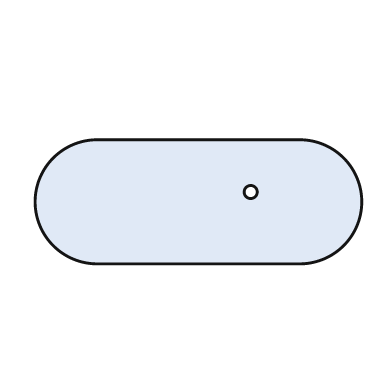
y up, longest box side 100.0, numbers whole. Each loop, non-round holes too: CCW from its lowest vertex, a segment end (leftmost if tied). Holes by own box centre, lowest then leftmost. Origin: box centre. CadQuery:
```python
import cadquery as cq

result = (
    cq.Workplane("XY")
    .moveTo(-31.0, -19.0)
    .lineTo(31.0, -19.0)
    .threePointArc((50.0, 0.0), (31.0, 19.0))
    .lineTo(-31.0, 19.0)
    .threePointArc((-50.0, 0.0), (-31.0, -19.0))
    .close()
    .moveTo(16.0, 3.0)
    .circle(2.0)
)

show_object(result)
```